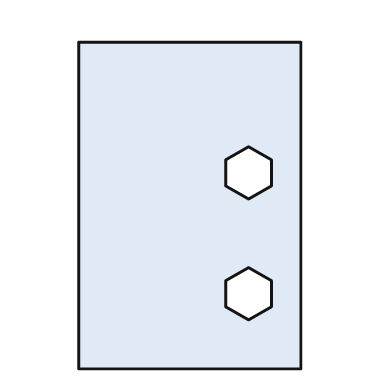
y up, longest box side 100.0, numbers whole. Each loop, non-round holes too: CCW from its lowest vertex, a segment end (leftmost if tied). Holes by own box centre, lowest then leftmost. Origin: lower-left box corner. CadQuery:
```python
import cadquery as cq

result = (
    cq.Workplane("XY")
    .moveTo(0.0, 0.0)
    .lineTo(68.0, 0.0)
    .lineTo(68.0, 100.0)
    .lineTo(0.0, 100.0)
    .close()
    .moveTo(52.0, 15.0)
    .lineTo(59.0, 19.0)
    .lineTo(59.0, 27.0)
    .lineTo(52.0, 31.0)
    .lineTo(45.0, 27.0)
    .lineTo(45.0, 19.0)
    .close()
    .moveTo(52.0, 52.0)
    .lineTo(59.0, 56.0)
    .lineTo(59.0, 64.0)
    .lineTo(52.0, 68.0)
    .lineTo(45.0, 64.0)
    .lineTo(45.0, 56.0)
    .close()
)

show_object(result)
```